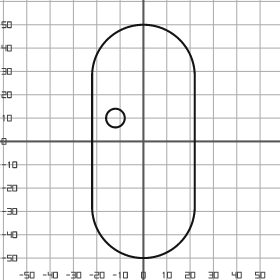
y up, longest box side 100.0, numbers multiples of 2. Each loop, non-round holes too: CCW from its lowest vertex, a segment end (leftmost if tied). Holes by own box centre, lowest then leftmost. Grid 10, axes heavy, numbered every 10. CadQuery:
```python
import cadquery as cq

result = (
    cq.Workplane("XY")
    .moveTo(-22.0, -28.0)
    .threePointArc((0.0, -50.0), (22.0, -28.0))
    .lineTo(22.0, 28.0)
    .threePointArc((0.0, 50.0), (-22.0, 28.0))
    .close()
    .moveTo(-12.0, 10.0)
    .circle(4.0)
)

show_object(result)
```